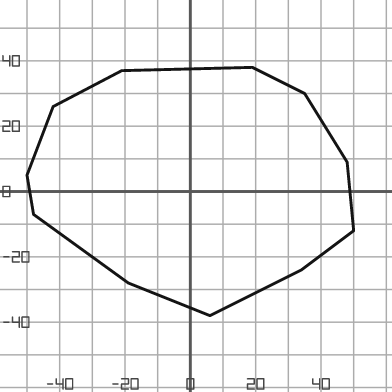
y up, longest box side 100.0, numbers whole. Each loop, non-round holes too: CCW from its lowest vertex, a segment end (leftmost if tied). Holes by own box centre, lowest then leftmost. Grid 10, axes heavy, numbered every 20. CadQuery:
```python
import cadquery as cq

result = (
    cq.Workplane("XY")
    .moveTo(6.0, -38.0)
    .lineTo(34.0, -24.0)
    .lineTo(50.0, -12.0)
    .lineTo(48.0, 9.0)
    .lineTo(35.0, 30.0)
    .lineTo(19.0, 38.0)
    .lineTo(-21.0, 37.0)
    .lineTo(-42.0, 26.0)
    .lineTo(-50.0, 5.0)
    .lineTo(-48.0, -7.0)
    .lineTo(-19.0, -28.0)
    .close()
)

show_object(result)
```